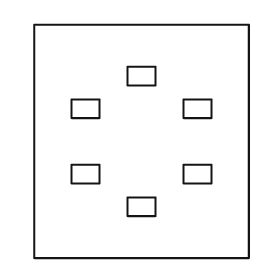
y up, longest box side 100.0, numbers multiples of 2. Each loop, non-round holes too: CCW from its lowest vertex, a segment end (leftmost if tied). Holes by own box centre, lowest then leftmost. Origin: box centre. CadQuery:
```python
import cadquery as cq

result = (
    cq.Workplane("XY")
    .moveTo(-46.0, -50.0)
    .lineTo(46.0, -50.0)
    .lineTo(46.0, 50.0)
    .lineTo(-46.0, 50.0)
    .close()
    .moveTo(-6.0, -32.0)
    .lineTo(6.0, -32.0)
    .lineTo(6.0, -24.0)
    .lineTo(-6.0, -24.0)
    .close()
    .moveTo(-30.0, -18.0)
    .lineTo(-18.0, -18.0)
    .lineTo(-18.0, -10.0)
    .lineTo(-30.0, -10.0)
    .close()
    .moveTo(18.0, -18.0)
    .lineTo(30.0, -18.0)
    .lineTo(30.0, -10.0)
    .lineTo(18.0, -10.0)
    .close()
    .moveTo(-30.0, 10.0)
    .lineTo(-18.0, 10.0)
    .lineTo(-18.0, 18.0)
    .lineTo(-30.0, 18.0)
    .close()
    .moveTo(18.0, 10.0)
    .lineTo(30.0, 10.0)
    .lineTo(30.0, 18.0)
    .lineTo(18.0, 18.0)
    .close()
    .moveTo(-6.0, 24.0)
    .lineTo(6.0, 24.0)
    .lineTo(6.0, 32.0)
    .lineTo(-6.0, 32.0)
    .close()
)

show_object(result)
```